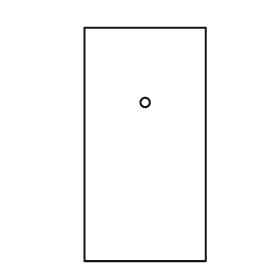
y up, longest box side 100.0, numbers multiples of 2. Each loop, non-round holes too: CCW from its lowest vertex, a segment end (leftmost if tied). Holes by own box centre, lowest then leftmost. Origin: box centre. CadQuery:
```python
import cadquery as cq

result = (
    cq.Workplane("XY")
    .moveTo(-26.0, -50.0)
    .lineTo(26.0, -50.0)
    .lineTo(26.0, 50.0)
    .lineTo(-26.0, 50.0)
    .close()
    .moveTo(0.0, 18.0)
    .circle(2.0)
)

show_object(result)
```